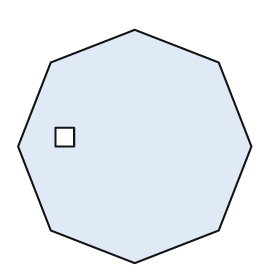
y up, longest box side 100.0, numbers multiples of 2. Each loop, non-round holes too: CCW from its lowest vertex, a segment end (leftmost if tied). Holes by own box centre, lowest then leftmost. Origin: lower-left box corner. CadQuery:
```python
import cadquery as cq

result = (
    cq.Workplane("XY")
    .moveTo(50.0, 0.0)
    .lineTo(86.0, 14.0)
    .lineTo(100.0, 50.0)
    .lineTo(86.0, 86.0)
    .lineTo(50.0, 100.0)
    .lineTo(14.0, 86.0)
    .lineTo(0.0, 50.0)
    .lineTo(14.0, 14.0)
    .close()
    .moveTo(16.0, 50.0)
    .lineTo(24.0, 50.0)
    .lineTo(24.0, 58.0)
    .lineTo(16.0, 58.0)
    .close()
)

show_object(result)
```